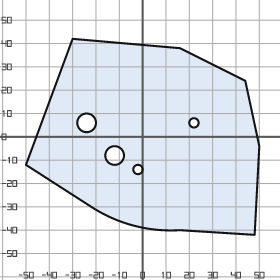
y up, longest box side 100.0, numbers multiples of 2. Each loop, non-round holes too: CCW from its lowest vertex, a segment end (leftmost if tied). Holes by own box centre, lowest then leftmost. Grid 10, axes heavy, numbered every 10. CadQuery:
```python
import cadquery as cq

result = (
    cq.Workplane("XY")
    .moveTo(48.0, -42.0)
    .lineTo(50.0, -4.0)
    .lineTo(44.0, 24.0)
    .lineTo(16.0, 38.0)
    .lineTo(-30.0, 42.0)
    .lineTo(-50.0, -12.0)
    .lineTo(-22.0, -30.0)
    .threePointArc((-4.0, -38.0), (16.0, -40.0))
    .close()
    .moveTo(-2.0, -14.0)
    .circle(2.0)
    .moveTo(-12.0, -8.0)
    .circle(4.0)
    .moveTo(-24.0, 6.0)
    .circle(4.0)
    .moveTo(22.0, 6.0)
    .circle(2.0)
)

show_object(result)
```